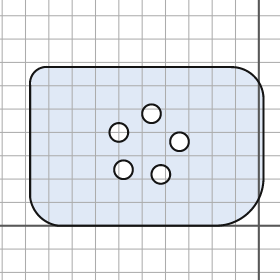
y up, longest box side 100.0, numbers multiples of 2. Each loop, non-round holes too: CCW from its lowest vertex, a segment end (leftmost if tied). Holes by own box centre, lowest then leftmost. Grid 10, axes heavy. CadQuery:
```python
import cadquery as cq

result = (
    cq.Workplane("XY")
    .moveTo(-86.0, 0.0)
    .lineTo(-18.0, 0.0)
    .threePointArc((-4.0, 6.0), (2.0, 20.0))
    .lineTo(2.0, 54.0)
    .threePointArc((-2.0, 64.0), (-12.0, 68.0))
    .lineTo(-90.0, 68.0)
    .threePointArc((-96.0, 66.0), (-98.0, 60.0))
    .lineTo(-98.0, 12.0)
    .threePointArc((-94.0, 4.0), (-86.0, 0.0))
    .close()
    .moveTo(-42.0, 22.0)
    .circle(4.0)
    .moveTo(-58.0, 24.0)
    .circle(4.0)
    .moveTo(-34.0, 36.0)
    .circle(4.0)
    .moveTo(-60.0, 40.0)
    .circle(4.0)
    .moveTo(-46.0, 48.0)
    .circle(4.0)
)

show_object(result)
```